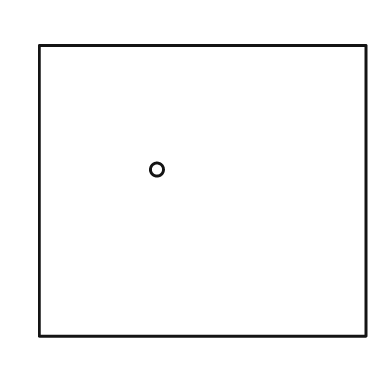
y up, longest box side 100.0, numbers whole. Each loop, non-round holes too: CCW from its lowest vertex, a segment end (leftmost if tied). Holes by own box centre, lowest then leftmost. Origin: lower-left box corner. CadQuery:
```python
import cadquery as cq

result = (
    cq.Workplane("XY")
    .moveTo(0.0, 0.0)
    .lineTo(100.0, 0.0)
    .lineTo(100.0, 89.0)
    .lineTo(0.0, 89.0)
    .close()
    .moveTo(36.0, 51.0)
    .circle(2.0)
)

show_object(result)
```